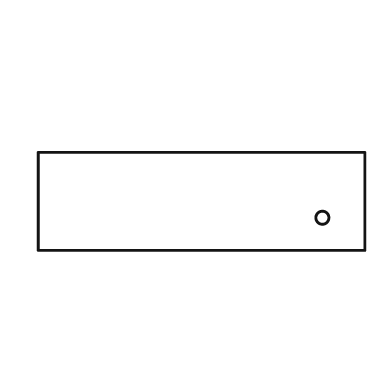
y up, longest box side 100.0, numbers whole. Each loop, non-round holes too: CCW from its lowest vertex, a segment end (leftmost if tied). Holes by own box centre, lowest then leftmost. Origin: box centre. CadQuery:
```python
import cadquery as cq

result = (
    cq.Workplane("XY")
    .moveTo(-50.0, -15.0)
    .lineTo(50.0, -15.0)
    .lineTo(50.0, 15.0)
    .lineTo(-50.0, 15.0)
    .close()
    .moveTo(37.0, -5.0)
    .circle(2.0)
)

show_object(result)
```